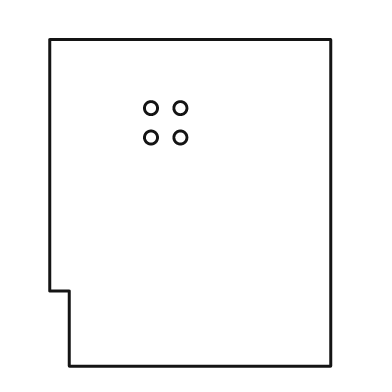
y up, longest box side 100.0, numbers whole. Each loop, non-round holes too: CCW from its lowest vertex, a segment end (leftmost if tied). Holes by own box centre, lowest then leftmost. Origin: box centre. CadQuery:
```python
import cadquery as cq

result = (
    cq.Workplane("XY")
    .moveTo(-37.0, -50.0)
    .lineTo(43.0, -50.0)
    .lineTo(43.0, 50.0)
    .lineTo(-43.0, 50.0)
    .lineTo(-43.0, -27.0)
    .lineTo(-37.0, -27.0)
    .close()
    .moveTo(-12.0, 20.0)
    .circle(2.0)
    .moveTo(-3.0, 20.0)
    .circle(2.0)
    .moveTo(-12.0, 29.0)
    .circle(2.0)
    .moveTo(-3.0, 29.0)
    .circle(2.0)
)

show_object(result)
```